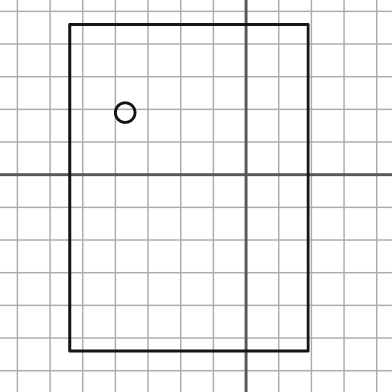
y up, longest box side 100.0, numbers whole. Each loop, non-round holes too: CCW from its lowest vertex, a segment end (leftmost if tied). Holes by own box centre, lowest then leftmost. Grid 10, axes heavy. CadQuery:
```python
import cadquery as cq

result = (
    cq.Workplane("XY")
    .moveTo(-54.0, -54.0)
    .lineTo(19.0, -54.0)
    .lineTo(19.0, 46.0)
    .lineTo(-54.0, 46.0)
    .close()
    .moveTo(-37.0, 19.0)
    .circle(3.0)
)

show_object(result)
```